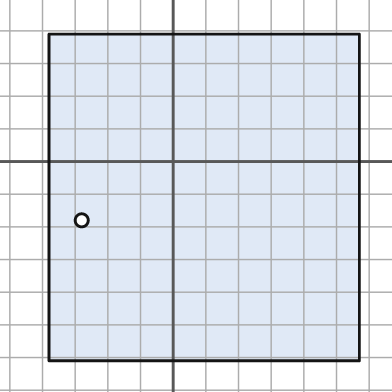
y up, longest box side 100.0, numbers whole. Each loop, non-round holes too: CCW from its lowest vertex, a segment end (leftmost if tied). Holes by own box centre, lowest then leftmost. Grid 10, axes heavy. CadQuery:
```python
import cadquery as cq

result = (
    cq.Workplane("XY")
    .moveTo(-38.0, -61.0)
    .lineTo(57.0, -61.0)
    .lineTo(57.0, 39.0)
    .lineTo(-38.0, 39.0)
    .close()
    .moveTo(-28.0, -18.0)
    .circle(2.0)
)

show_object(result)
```